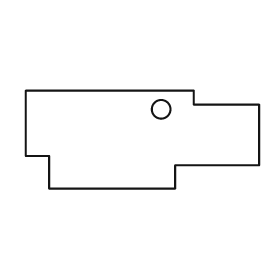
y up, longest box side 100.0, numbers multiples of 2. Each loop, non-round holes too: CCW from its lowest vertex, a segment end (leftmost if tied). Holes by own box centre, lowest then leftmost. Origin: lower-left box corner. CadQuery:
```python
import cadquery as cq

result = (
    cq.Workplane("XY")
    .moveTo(10.0, 0.0)
    .lineTo(64.0, 0.0)
    .lineTo(64.0, 10.0)
    .lineTo(100.0, 10.0)
    .lineTo(100.0, 36.0)
    .lineTo(72.0, 36.0)
    .lineTo(72.0, 42.0)
    .lineTo(0.0, 42.0)
    .lineTo(0.0, 14.0)
    .lineTo(10.0, 14.0)
    .close()
    .moveTo(58.0, 34.0)
    .circle(4.0)
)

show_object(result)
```